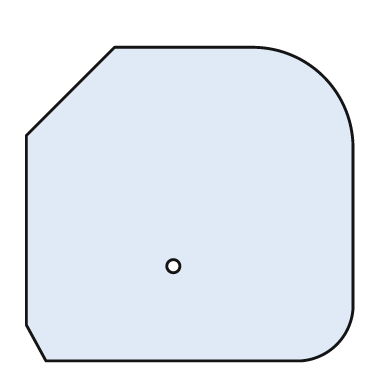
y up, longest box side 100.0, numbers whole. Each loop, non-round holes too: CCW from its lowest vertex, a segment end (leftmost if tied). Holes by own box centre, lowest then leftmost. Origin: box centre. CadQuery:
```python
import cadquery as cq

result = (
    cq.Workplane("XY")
    .moveTo(-44.0, -48.0)
    .lineTo(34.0, -48.0)
    .threePointArc((45.0, -43.0), (50.0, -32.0))
    .lineTo(50.0, 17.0)
    .threePointArc((41.0, 39.0), (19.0, 48.0))
    .lineTo(-23.0, 48.0)
    .lineTo(-50.0, 21.0)
    .lineTo(-50.0, -37.0)
    .close()
    .moveTo(-5.0, -19.0)
    .circle(2.0)
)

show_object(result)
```